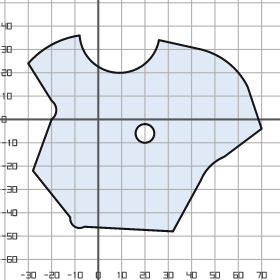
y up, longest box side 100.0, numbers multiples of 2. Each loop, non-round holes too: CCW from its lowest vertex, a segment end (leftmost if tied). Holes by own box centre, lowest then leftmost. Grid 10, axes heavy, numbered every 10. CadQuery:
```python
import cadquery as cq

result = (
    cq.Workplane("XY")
    .moveTo(32.0, -48.0)
    .lineTo(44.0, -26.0)
    .threePointArc((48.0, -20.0), (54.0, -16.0))
    .lineTo(70.0, -4.0)
    .lineTo(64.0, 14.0)
    .threePointArc((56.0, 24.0), (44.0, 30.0))
    .lineTo(26.0, 34.0)
    .threePointArc((8.0, 20.0), (-8.0, 36.0))
    .threePointArc((-20.0, 32.0), (-30.0, 24.0))
    .lineTo(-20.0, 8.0)
    .threePointArc((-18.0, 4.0), (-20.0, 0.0))
    .lineTo(-28.0, -22.0)
    .lineTo(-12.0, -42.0)
    .threePointArc((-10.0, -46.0), (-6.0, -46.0))
    .close()
    .moveTo(20.0, -6.0)
    .circle(4.0)
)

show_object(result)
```